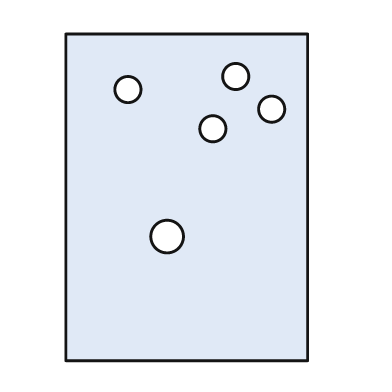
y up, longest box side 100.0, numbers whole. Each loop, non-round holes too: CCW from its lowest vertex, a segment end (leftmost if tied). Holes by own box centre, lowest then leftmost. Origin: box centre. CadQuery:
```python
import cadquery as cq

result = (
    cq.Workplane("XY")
    .moveTo(-37.0, -50.0)
    .lineTo(37.0, -50.0)
    .lineTo(37.0, 50.0)
    .lineTo(-37.0, 50.0)
    .close()
    .moveTo(-6.0, -12.0)
    .circle(5.0)
    .moveTo(8.0, 21.0)
    .circle(4.0)
    .moveTo(26.0, 27.0)
    .circle(4.0)
    .moveTo(-18.0, 33.0)
    .circle(4.0)
    .moveTo(15.0, 37.0)
    .circle(4.0)
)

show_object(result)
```